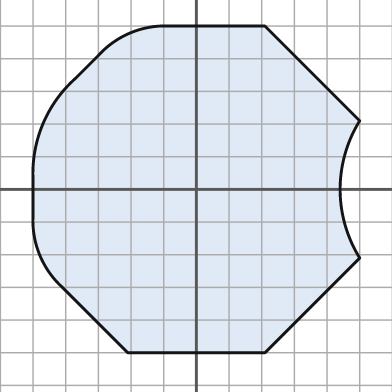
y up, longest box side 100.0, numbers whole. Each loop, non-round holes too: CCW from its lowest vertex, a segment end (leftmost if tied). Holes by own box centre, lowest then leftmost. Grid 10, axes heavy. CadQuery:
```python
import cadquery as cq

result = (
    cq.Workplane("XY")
    .moveTo(-21.0, -50.0)
    .lineTo(21.0, -50.0)
    .lineTo(50.0, -21.0)
    .threePointArc((44.0, 0.0), (50.0, 21.0))
    .lineTo(21.0, 50.0)
    .lineTo(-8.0, 50.0)
    .threePointArc((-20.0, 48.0), (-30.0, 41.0))
    .lineTo(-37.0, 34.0)
    .threePointArc((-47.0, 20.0), (-50.0, 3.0))
    .lineTo(-50.0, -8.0)
    .threePointArc((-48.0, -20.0), (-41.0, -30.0))
    .close()
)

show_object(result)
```